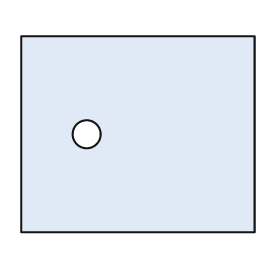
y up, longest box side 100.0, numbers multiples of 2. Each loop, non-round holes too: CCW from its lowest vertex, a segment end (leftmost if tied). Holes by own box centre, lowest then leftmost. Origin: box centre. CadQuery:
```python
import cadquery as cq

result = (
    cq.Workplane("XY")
    .moveTo(-50.0, -42.0)
    .lineTo(50.0, -42.0)
    .lineTo(50.0, 42.0)
    .lineTo(-50.0, 42.0)
    .close()
    .moveTo(-22.0, 0.0)
    .circle(6.0)
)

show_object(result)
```